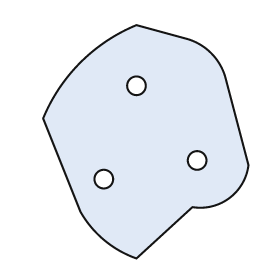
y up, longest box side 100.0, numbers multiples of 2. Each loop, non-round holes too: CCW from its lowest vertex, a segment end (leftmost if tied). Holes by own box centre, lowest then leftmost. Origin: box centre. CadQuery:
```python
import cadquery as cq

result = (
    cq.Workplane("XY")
    .moveTo(-4.0, -50.0)
    .lineTo(20.0, -28.0)
    .threePointArc((36.0, -24.0), (44.0, -10.0))
    .lineTo(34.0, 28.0)
    .threePointArc((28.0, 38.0), (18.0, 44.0))
    .lineTo(-4.0, 50.0)
    .threePointArc((-28.0, 34.0), (-44.0, 10.0))
    .lineTo(-28.0, -30.0)
    .threePointArc((-18.0, -42.0), (-4.0, -50.0))
    .close()
    .moveTo(-18.0, -16.0)
    .circle(4.0)
    .moveTo(22.0, -8.0)
    .circle(4.0)
    .moveTo(-4.0, 24.0)
    .circle(4.0)
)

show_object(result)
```